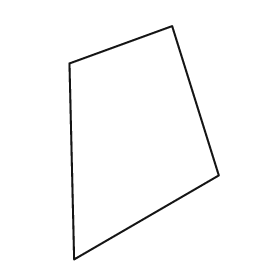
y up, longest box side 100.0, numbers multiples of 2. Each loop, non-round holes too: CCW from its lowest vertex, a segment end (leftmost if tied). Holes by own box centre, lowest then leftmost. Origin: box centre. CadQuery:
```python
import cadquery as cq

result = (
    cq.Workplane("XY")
    .moveTo(-30.0, -50.0)
    .lineTo(32.0, -14.0)
    .lineTo(12.0, 50.0)
    .lineTo(-32.0, 34.0)
    .close()
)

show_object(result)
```